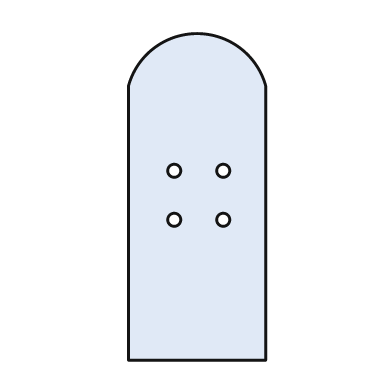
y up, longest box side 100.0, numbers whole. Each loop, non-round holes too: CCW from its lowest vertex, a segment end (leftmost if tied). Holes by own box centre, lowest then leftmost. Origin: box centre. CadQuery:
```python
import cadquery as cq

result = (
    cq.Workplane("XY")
    .moveTo(-21.0, -50.0)
    .lineTo(21.0, -50.0)
    .lineTo(21.0, 34.0)
    .threePointArc((0.0, 50.0), (-21.0, 34.0))
    .close()
    .moveTo(-7.0, -7.0)
    .circle(2.0)
    .moveTo(8.0, -7.0)
    .circle(2.0)
    .moveTo(-7.0, 8.0)
    .circle(2.0)
    .moveTo(8.0, 8.0)
    .circle(2.0)
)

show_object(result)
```